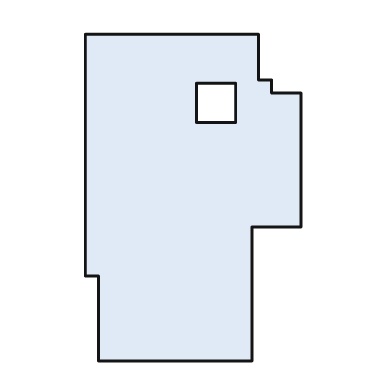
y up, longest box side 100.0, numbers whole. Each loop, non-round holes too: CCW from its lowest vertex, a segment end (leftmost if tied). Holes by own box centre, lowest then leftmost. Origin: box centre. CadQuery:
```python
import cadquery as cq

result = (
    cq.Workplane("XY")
    .moveTo(-29.0, -50.0)
    .lineTo(18.0, -50.0)
    .lineTo(18.0, -9.0)
    .lineTo(33.0, -9.0)
    .lineTo(33.0, 32.0)
    .lineTo(24.0, 32.0)
    .lineTo(24.0, 36.0)
    .lineTo(20.0, 36.0)
    .lineTo(20.0, 50.0)
    .lineTo(-33.0, 50.0)
    .lineTo(-33.0, -24.0)
    .lineTo(-29.0, -24.0)
    .close()
    .moveTo(1.0, 23.0)
    .lineTo(13.0, 23.0)
    .lineTo(13.0, 35.0)
    .lineTo(1.0, 35.0)
    .close()
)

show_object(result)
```